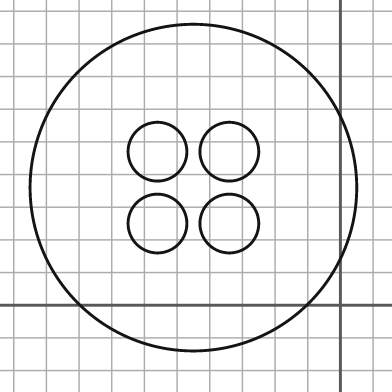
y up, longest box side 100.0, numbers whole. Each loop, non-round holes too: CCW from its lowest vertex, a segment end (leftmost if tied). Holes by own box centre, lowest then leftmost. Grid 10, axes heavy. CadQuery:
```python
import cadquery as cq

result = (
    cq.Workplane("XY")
    .moveTo(-45.0, 36.0)
    .circle(50.0)
    .moveTo(-56.0, 25.0)
    .circle(9.0)
    .moveTo(-34.0, 25.0)
    .circle(9.0)
    .moveTo(-56.0, 47.0)
    .circle(9.0)
    .moveTo(-34.0, 47.0)
    .circle(9.0)
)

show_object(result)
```